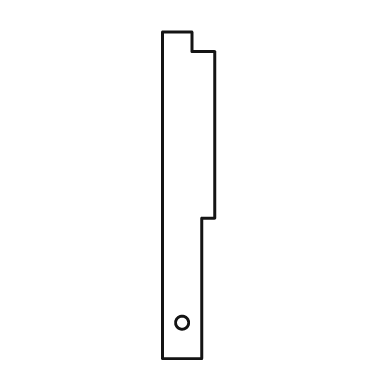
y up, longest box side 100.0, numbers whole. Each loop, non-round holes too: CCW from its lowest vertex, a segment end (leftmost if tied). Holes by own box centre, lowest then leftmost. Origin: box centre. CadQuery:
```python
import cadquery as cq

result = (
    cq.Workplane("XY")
    .moveTo(-8.0, -50.0)
    .lineTo(4.0, -50.0)
    .lineTo(4.0, -7.0)
    .lineTo(8.0, -7.0)
    .lineTo(8.0, 44.0)
    .lineTo(1.0, 44.0)
    .lineTo(1.0, 50.0)
    .lineTo(-8.0, 50.0)
    .close()
    .moveTo(-2.0, -39.0)
    .circle(2.0)
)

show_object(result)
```